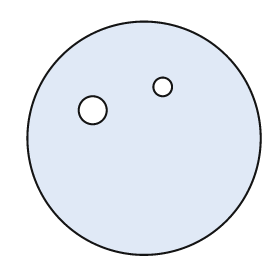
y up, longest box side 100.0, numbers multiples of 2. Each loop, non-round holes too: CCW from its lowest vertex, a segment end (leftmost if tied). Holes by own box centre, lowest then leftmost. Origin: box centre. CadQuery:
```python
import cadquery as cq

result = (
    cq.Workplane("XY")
    .moveTo(0.0, 0.0)
    .circle(50.0)
    .moveTo(-22.0, 12.0)
    .circle(6.0)
    .moveTo(8.0, 22.0)
    .circle(4.0)
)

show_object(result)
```